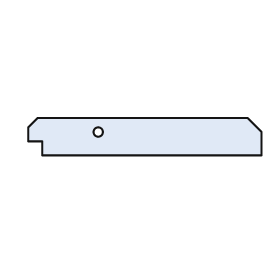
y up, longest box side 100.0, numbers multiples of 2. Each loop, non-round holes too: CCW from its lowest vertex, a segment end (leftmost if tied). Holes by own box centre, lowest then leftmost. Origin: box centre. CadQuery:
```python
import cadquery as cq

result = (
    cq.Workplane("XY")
    .moveTo(-44.0, -8.0)
    .lineTo(50.0, -8.0)
    .lineTo(50.0, 2.0)
    .lineTo(44.0, 8.0)
    .lineTo(-46.0, 8.0)
    .lineTo(-50.0, 4.0)
    .lineTo(-50.0, -2.0)
    .lineTo(-44.0, -2.0)
    .close()
    .moveTo(-20.0, 2.0)
    .circle(2.0)
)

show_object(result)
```